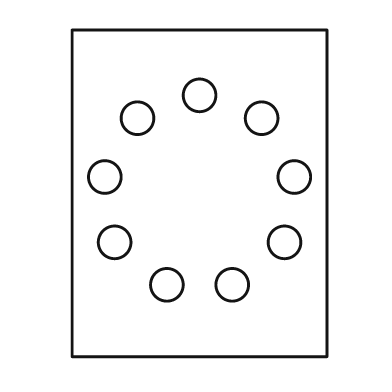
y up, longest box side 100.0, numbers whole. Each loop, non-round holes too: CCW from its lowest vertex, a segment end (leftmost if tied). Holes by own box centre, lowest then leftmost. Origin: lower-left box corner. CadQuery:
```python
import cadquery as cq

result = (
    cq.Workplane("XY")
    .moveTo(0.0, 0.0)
    .lineTo(78.0, 0.0)
    .lineTo(78.0, 100.0)
    .lineTo(0.0, 100.0)
    .close()
    .moveTo(29.0, 22.0)
    .circle(5.0)
    .moveTo(49.0, 22.0)
    .circle(5.0)
    .moveTo(13.0, 35.0)
    .circle(5.0)
    .moveTo(65.0, 35.0)
    .circle(5.0)
    .moveTo(10.0, 55.0)
    .circle(5.0)
    .moveTo(68.0, 55.0)
    .circle(5.0)
    .moveTo(20.0, 73.0)
    .circle(5.0)
    .moveTo(58.0, 73.0)
    .circle(5.0)
    .moveTo(39.0, 80.0)
    .circle(5.0)
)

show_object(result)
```